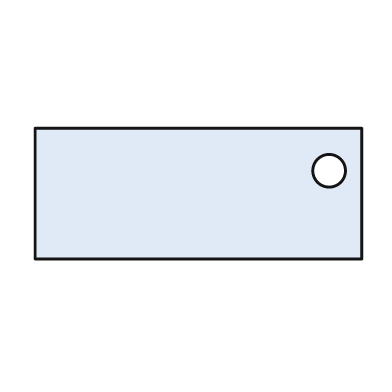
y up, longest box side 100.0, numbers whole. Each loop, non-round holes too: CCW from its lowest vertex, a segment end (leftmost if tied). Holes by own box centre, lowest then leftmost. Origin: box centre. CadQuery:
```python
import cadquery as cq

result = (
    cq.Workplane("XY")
    .moveTo(-50.0, -20.0)
    .lineTo(50.0, -20.0)
    .lineTo(50.0, 20.0)
    .lineTo(-50.0, 20.0)
    .close()
    .moveTo(40.0, 7.0)
    .circle(5.0)
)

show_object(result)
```